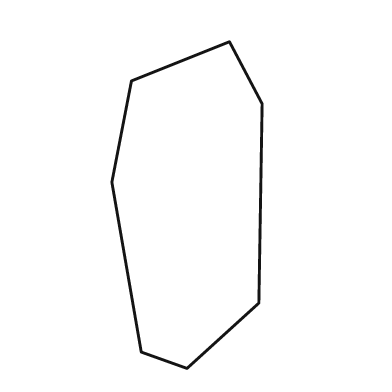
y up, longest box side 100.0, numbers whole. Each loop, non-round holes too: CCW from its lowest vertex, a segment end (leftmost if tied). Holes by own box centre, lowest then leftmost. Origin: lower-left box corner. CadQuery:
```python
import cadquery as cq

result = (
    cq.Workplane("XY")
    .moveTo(23.0, 0.0)
    .lineTo(45.0, 20.0)
    .lineTo(46.0, 81.0)
    .lineTo(36.0, 100.0)
    .lineTo(6.0, 88.0)
    .lineTo(0.0, 57.0)
    .lineTo(9.0, 5.0)
    .close()
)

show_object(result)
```